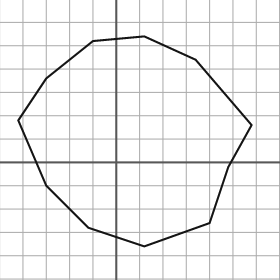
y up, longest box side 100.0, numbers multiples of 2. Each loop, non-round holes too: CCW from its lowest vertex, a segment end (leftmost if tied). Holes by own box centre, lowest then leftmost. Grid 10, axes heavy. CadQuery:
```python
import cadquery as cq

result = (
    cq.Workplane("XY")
    .moveTo(12.0, -36.0)
    .lineTo(40.0, -26.0)
    .lineTo(48.0, -2.0)
    .lineTo(58.0, 16.0)
    .lineTo(34.0, 44.0)
    .lineTo(12.0, 54.0)
    .lineTo(-10.0, 52.0)
    .lineTo(-30.0, 36.0)
    .lineTo(-42.0, 18.0)
    .lineTo(-30.0, -10.0)
    .lineTo(-12.0, -28.0)
    .close()
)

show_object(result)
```